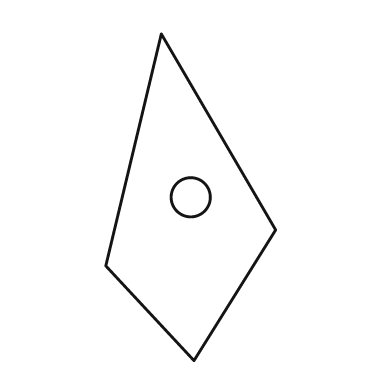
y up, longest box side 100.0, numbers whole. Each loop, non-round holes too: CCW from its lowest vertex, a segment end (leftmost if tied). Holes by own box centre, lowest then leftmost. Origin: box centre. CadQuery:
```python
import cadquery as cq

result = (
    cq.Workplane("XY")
    .moveTo(1.0, -50.0)
    .lineTo(26.0, -10.0)
    .lineTo(-9.0, 50.0)
    .lineTo(-26.0, -21.0)
    .close()
    .moveTo(0.0, 0.0)
    .circle(6.0)
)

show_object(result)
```